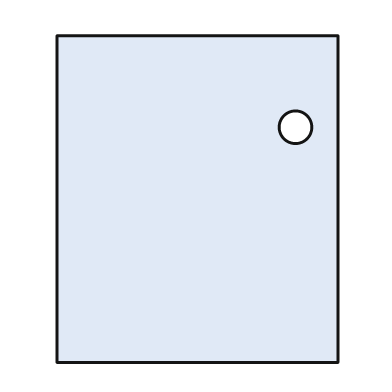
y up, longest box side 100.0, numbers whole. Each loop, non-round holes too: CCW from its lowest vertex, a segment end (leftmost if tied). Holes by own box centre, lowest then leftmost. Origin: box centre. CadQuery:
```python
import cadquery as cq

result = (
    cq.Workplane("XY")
    .moveTo(-43.0, -50.0)
    .lineTo(43.0, -50.0)
    .lineTo(43.0, 50.0)
    .lineTo(-43.0, 50.0)
    .close()
    .moveTo(30.0, 22.0)
    .circle(5.0)
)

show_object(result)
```